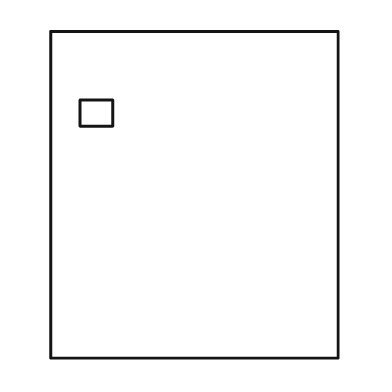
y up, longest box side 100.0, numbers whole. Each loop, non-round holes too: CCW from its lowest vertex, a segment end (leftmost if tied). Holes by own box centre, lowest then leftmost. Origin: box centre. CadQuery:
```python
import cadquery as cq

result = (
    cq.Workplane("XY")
    .moveTo(-44.0, -50.0)
    .lineTo(44.0, -50.0)
    .lineTo(44.0, 50.0)
    .lineTo(-44.0, 50.0)
    .close()
    .moveTo(-35.0, 21.0)
    .lineTo(-25.0, 21.0)
    .lineTo(-25.0, 29.0)
    .lineTo(-35.0, 29.0)
    .close()
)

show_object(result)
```